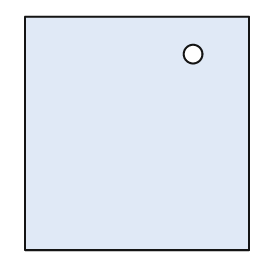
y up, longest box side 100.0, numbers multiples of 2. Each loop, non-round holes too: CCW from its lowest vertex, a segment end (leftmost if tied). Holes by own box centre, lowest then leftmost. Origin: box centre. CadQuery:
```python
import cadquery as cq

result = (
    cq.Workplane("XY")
    .moveTo(-48.0, -50.0)
    .lineTo(48.0, -50.0)
    .lineTo(48.0, 50.0)
    .lineTo(-48.0, 50.0)
    .close()
    .moveTo(24.0, 34.0)
    .circle(4.0)
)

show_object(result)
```